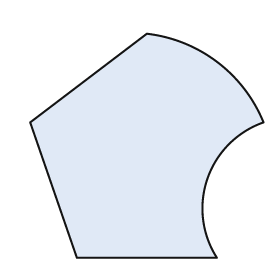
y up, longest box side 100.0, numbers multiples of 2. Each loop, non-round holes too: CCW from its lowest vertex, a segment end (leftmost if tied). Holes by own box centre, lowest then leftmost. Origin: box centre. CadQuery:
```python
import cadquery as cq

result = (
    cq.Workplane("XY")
    .moveTo(-30.0, -48.0)
    .lineTo(30.0, -48.0)
    .threePointArc((26.0, -14.0), (50.0, 10.0))
    .threePointArc((30.0, 36.0), (0.0, 48.0))
    .lineTo(-50.0, 10.0)
    .close()
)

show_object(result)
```